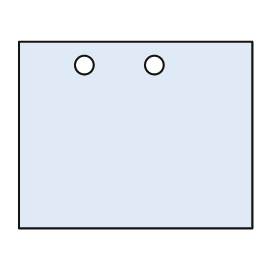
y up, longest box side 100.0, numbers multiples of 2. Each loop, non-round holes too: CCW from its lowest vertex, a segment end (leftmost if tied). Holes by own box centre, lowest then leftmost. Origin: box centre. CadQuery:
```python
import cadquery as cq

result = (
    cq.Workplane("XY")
    .moveTo(-50.0, -40.0)
    .lineTo(50.0, -40.0)
    .lineTo(50.0, 40.0)
    .lineTo(-50.0, 40.0)
    .close()
    .moveTo(-22.0, 30.0)
    .circle(4.0)
    .moveTo(8.0, 30.0)
    .circle(4.0)
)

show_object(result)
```